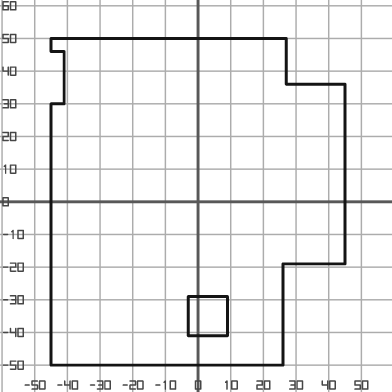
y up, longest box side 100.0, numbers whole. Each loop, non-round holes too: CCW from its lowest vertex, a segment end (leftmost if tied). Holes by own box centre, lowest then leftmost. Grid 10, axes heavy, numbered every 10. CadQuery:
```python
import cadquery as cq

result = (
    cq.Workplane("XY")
    .moveTo(-45.0, -50.0)
    .lineTo(26.0, -50.0)
    .lineTo(26.0, -19.0)
    .lineTo(45.0, -19.0)
    .lineTo(45.0, 36.0)
    .lineTo(27.0, 36.0)
    .lineTo(27.0, 50.0)
    .lineTo(-45.0, 50.0)
    .lineTo(-45.0, 46.0)
    .lineTo(-41.0, 46.0)
    .lineTo(-41.0, 30.0)
    .lineTo(-45.0, 30.0)
    .close()
    .moveTo(-3.0, -41.0)
    .lineTo(9.0, -41.0)
    .lineTo(9.0, -29.0)
    .lineTo(-3.0, -29.0)
    .close()
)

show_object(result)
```